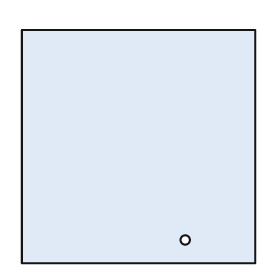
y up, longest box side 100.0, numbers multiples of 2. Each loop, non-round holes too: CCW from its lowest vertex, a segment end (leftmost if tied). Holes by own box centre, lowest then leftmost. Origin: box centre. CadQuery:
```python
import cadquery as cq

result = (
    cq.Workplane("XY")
    .moveTo(-50.0, -50.0)
    .lineTo(50.0, -50.0)
    .lineTo(50.0, 50.0)
    .lineTo(-50.0, 50.0)
    .close()
    .moveTo(20.0, -40.0)
    .circle(2.0)
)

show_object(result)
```